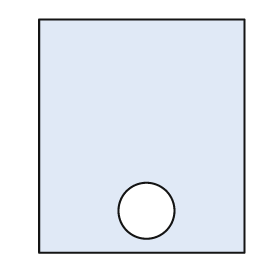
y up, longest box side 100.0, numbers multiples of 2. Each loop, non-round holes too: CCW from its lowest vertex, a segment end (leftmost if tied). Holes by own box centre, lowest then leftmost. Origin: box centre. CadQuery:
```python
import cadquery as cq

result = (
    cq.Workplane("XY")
    .moveTo(-44.0, -50.0)
    .lineTo(44.0, -50.0)
    .lineTo(44.0, 50.0)
    .lineTo(-44.0, 50.0)
    .close()
    .moveTo(2.0, -32.0)
    .circle(12.0)
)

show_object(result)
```